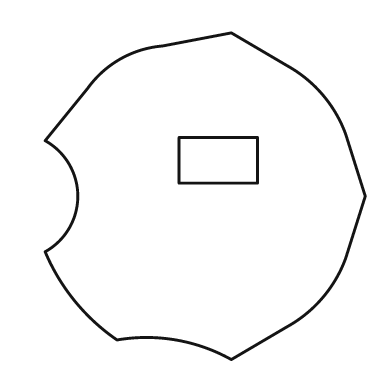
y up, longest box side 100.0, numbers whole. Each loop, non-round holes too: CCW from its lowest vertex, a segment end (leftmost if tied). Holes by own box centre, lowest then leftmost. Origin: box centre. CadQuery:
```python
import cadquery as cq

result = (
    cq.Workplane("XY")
    .moveTo(8.0, -50.0)
    .lineTo(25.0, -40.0)
    .threePointArc((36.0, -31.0), (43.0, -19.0))
    .lineTo(49.0, 0.0)
    .lineTo(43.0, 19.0)
    .threePointArc((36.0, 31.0), (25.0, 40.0))
    .lineTo(8.0, 50.0)
    .lineTo(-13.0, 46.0)
    .threePointArc((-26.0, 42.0), (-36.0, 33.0))
    .lineTo(-49.0, 17.0)
    .threePointArc((-39.0, 0.0), (-49.0, -17.0))
    .threePointArc((-40.0, -32.0), (-27.0, -44.0))
    .threePointArc((-9.0, -44.0), (8.0, -50.0))
    .close()
    .moveTo(-8.0, 4.0)
    .lineTo(16.0, 4.0)
    .lineTo(16.0, 18.0)
    .lineTo(-8.0, 18.0)
    .close()
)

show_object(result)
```